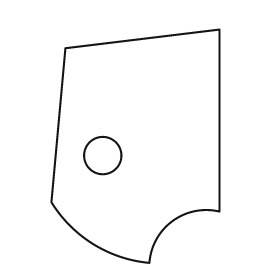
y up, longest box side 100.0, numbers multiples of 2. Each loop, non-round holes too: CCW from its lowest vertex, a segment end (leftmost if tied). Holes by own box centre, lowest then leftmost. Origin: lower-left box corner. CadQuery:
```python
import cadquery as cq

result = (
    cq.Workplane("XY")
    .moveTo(42.0, 0.0)
    .threePointArc((52.0, 18.0), (72.0, 22.0))
    .lineTo(72.0, 100.0)
    .lineTo(6.0, 92.0)
    .lineTo(0.0, 26.0)
    .threePointArc((18.0, 8.0), (42.0, 0.0))
    .close()
    .moveTo(22.0, 46.0)
    .circle(8.0)
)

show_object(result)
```